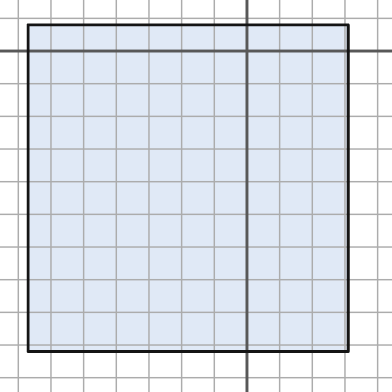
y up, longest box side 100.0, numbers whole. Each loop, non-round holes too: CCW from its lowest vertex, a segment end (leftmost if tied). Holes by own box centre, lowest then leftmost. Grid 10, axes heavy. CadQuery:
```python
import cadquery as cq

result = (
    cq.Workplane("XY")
    .moveTo(-67.0, -92.0)
    .lineTo(31.0, -92.0)
    .lineTo(31.0, 8.0)
    .lineTo(-67.0, 8.0)
    .close()
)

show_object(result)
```